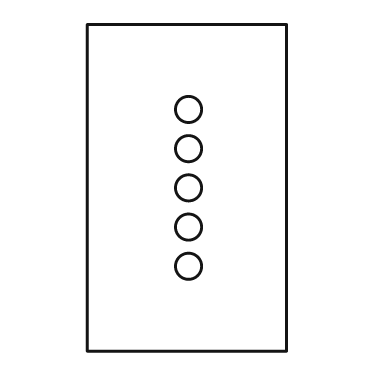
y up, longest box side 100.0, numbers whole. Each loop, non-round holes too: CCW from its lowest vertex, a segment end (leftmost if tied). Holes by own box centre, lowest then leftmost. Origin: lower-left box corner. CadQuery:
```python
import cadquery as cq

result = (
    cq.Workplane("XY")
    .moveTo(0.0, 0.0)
    .lineTo(61.0, 0.0)
    .lineTo(61.0, 100.0)
    .lineTo(0.0, 100.0)
    .close()
    .moveTo(31.0, 26.0)
    .circle(4.0)
    .moveTo(31.0, 38.0)
    .circle(4.0)
    .moveTo(31.0, 50.0)
    .circle(4.0)
    .moveTo(31.0, 62.0)
    .circle(4.0)
    .moveTo(31.0, 74.0)
    .circle(4.0)
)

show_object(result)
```